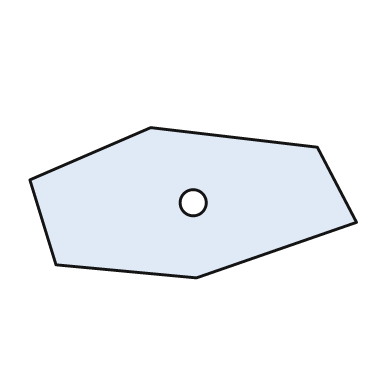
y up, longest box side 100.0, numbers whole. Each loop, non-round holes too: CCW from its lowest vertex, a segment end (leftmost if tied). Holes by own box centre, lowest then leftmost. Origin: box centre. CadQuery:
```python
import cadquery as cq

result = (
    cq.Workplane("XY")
    .moveTo(1.0, -23.0)
    .lineTo(50.0, -6.0)
    .lineTo(38.0, 17.0)
    .lineTo(-13.0, 23.0)
    .lineTo(-50.0, 7.0)
    .lineTo(-42.0, -19.0)
    .close()
    .moveTo(0.0, 0.0)
    .circle(4.0)
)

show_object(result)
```